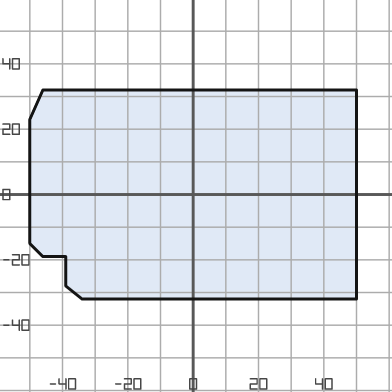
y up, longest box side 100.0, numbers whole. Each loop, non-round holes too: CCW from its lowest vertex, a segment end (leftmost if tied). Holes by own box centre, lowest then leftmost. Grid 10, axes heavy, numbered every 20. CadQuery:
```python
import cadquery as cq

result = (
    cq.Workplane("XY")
    .moveTo(-34.0, -32.0)
    .lineTo(50.0, -32.0)
    .lineTo(50.0, 32.0)
    .lineTo(-46.0, 32.0)
    .lineTo(-50.0, 23.0)
    .lineTo(-50.0, -15.0)
    .lineTo(-46.0, -19.0)
    .lineTo(-39.0, -19.0)
    .lineTo(-39.0, -28.0)
    .close()
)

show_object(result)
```